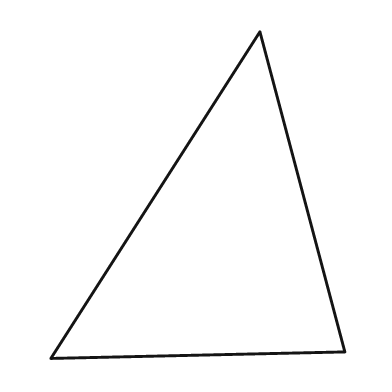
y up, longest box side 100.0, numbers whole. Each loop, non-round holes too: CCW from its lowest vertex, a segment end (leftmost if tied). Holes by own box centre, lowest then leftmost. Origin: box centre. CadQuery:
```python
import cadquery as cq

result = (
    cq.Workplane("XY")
    .moveTo(-45.0, -50.0)
    .lineTo(45.0, -48.0)
    .lineTo(19.0, 50.0)
    .close()
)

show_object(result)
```